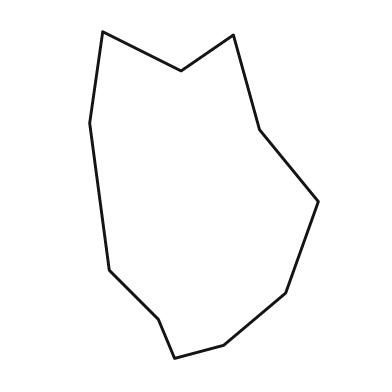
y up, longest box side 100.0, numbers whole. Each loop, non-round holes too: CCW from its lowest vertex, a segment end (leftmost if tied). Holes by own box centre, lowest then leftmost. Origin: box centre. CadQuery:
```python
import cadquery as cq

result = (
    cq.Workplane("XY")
    .moveTo(-9.0, -50.0)
    .lineTo(6.0, -46.0)
    .lineTo(25.0, -30.0)
    .lineTo(35.0, -2.0)
    .lineTo(17.0, 20.0)
    .lineTo(9.0, 49.0)
    .lineTo(-7.0, 38.0)
    .lineTo(-31.0, 50.0)
    .lineTo(-35.0, 22.0)
    .lineTo(-29.0, -23.0)
    .lineTo(-14.0, -38.0)
    .close()
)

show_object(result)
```